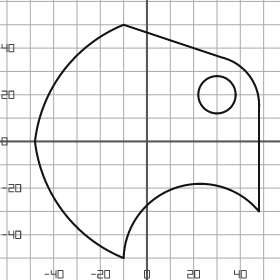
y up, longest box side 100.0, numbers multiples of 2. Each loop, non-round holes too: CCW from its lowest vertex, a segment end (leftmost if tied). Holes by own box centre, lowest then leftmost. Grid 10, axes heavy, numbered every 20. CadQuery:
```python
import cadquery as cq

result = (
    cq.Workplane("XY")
    .moveTo(-10.0, -50.0)
    .threePointArc((12.0, -20.0), (48.0, -30.0))
    .lineTo(48.0, 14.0)
    .threePointArc((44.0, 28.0), (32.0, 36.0))
    .lineTo(-10.0, 50.0)
    .threePointArc((-36.0, 30.0), (-48.0, 0.0))
    .threePointArc((-36.0, -30.0), (-10.0, -50.0))
    .close()
    .moveTo(30.0, 20.0)
    .circle(8.0)
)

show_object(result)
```